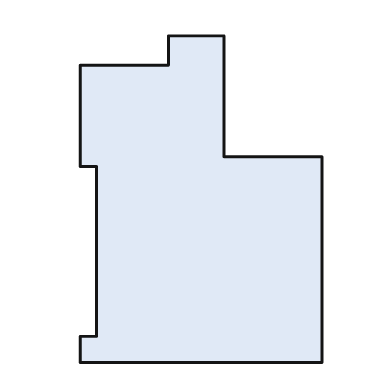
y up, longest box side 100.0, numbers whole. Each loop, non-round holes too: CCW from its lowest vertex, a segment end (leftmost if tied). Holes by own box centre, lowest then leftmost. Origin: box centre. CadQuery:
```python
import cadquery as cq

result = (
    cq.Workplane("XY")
    .moveTo(-37.0, -50.0)
    .lineTo(37.0, -50.0)
    .lineTo(37.0, 13.0)
    .lineTo(7.0, 13.0)
    .lineTo(7.0, 50.0)
    .lineTo(-10.0, 50.0)
    .lineTo(-10.0, 41.0)
    .lineTo(-37.0, 41.0)
    .lineTo(-37.0, 10.0)
    .lineTo(-32.0, 10.0)
    .lineTo(-32.0, -42.0)
    .lineTo(-37.0, -42.0)
    .close()
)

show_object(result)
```